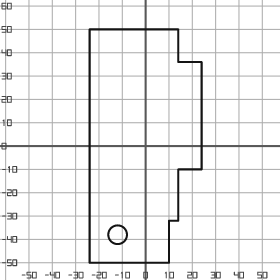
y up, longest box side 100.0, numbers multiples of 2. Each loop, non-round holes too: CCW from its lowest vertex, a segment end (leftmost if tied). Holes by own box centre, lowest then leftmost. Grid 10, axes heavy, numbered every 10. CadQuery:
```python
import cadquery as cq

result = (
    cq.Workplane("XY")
    .moveTo(-24.0, -50.0)
    .lineTo(10.0, -50.0)
    .lineTo(10.0, -32.0)
    .lineTo(14.0, -32.0)
    .lineTo(14.0, -10.0)
    .lineTo(24.0, -10.0)
    .lineTo(24.0, 36.0)
    .lineTo(14.0, 36.0)
    .lineTo(14.0, 50.0)
    .lineTo(-24.0, 50.0)
    .close()
    .moveTo(-12.0, -38.0)
    .circle(4.0)
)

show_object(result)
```